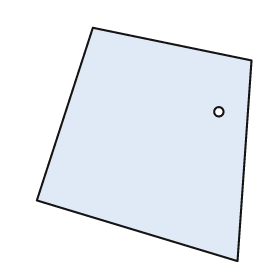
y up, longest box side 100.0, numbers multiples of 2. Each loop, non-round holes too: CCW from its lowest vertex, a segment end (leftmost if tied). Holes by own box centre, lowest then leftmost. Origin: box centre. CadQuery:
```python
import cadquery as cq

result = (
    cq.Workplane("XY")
    .moveTo(40.0, -50.0)
    .lineTo(46.0, 36.0)
    .lineTo(-22.0, 50.0)
    .lineTo(-46.0, -24.0)
    .close()
    .moveTo(32.0, 14.0)
    .circle(2.0)
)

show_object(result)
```